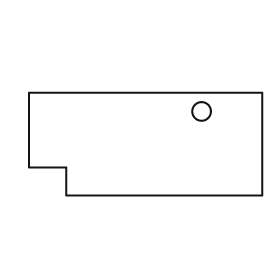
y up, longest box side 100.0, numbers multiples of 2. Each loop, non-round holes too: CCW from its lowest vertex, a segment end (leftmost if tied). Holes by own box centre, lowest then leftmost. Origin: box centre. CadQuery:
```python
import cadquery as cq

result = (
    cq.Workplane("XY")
    .moveTo(-34.0, -22.0)
    .lineTo(50.0, -22.0)
    .lineTo(50.0, 22.0)
    .lineTo(-50.0, 22.0)
    .lineTo(-50.0, -10.0)
    .lineTo(-34.0, -10.0)
    .close()
    .moveTo(24.0, 14.0)
    .circle(4.0)
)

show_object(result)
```